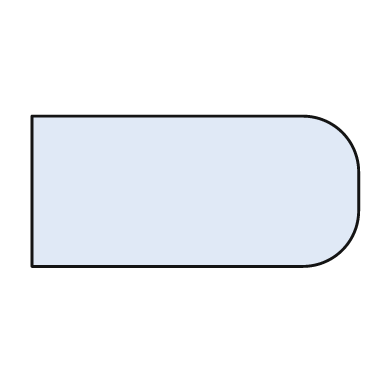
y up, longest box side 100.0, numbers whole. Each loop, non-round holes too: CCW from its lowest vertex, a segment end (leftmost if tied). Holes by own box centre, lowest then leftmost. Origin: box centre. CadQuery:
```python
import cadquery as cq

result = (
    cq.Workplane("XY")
    .moveTo(-50.0, -23.0)
    .lineTo(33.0, -23.0)
    .threePointArc((45.0, -18.0), (50.0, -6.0))
    .lineTo(50.0, 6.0)
    .threePointArc((45.0, 18.0), (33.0, 23.0))
    .lineTo(-50.0, 23.0)
    .close()
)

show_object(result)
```